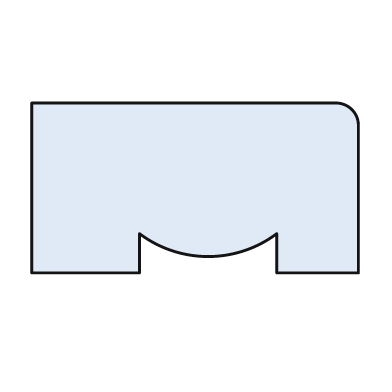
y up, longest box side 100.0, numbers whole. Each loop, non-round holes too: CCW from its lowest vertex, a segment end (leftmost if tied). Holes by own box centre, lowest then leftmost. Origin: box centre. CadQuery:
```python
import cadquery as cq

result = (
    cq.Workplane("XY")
    .moveTo(-50.0, -26.0)
    .lineTo(-17.0, -26.0)
    .lineTo(-17.0, -14.0)
    .threePointArc((4.0, -21.0), (25.0, -14.0))
    .lineTo(25.0, -26.0)
    .lineTo(50.0, -26.0)
    .lineTo(50.0, 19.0)
    .threePointArc((48.0, 24.0), (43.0, 26.0))
    .lineTo(-50.0, 26.0)
    .close()
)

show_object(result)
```